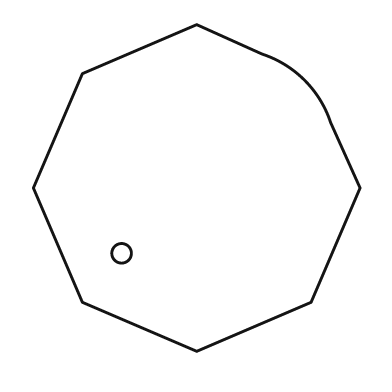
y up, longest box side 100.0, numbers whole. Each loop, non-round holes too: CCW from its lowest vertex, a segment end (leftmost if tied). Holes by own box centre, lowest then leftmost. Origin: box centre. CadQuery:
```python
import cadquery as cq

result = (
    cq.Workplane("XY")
    .moveTo(0.0, -50.0)
    .lineTo(35.0, -35.0)
    .lineTo(50.0, 0.0)
    .lineTo(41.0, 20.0)
    .threePointArc((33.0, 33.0), (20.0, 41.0))
    .lineTo(0.0, 50.0)
    .lineTo(-35.0, 35.0)
    .lineTo(-50.0, 0.0)
    .lineTo(-35.0, -35.0)
    .close()
    .moveTo(-23.0, -20.0)
    .circle(3.0)
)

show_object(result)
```